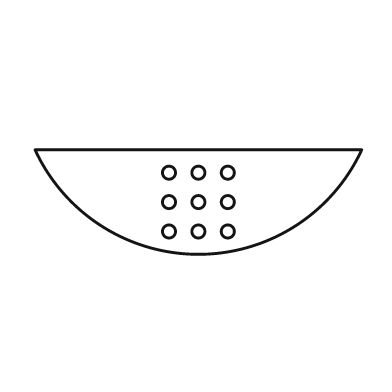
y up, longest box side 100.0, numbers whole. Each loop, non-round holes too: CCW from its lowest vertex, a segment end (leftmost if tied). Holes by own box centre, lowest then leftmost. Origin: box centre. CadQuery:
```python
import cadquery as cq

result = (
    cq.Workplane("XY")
    .moveTo(-50.0, 16.0)
    .threePointArc((0.0, -16.0), (50.0, 16.0))
    .close()
    .moveTo(-9.0, -9.0)
    .circle(2.0)
    .moveTo(0.0, -9.0)
    .circle(2.0)
    .moveTo(9.0, -9.0)
    .circle(2.0)
    .moveTo(-9.0, 0.0)
    .circle(2.0)
    .moveTo(0.0, 0.0)
    .circle(2.0)
    .moveTo(9.0, 0.0)
    .circle(2.0)
    .moveTo(-9.0, 9.0)
    .circle(2.0)
    .moveTo(0.0, 9.0)
    .circle(2.0)
    .moveTo(9.0, 9.0)
    .circle(2.0)
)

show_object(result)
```